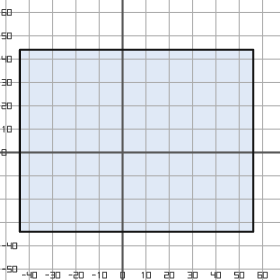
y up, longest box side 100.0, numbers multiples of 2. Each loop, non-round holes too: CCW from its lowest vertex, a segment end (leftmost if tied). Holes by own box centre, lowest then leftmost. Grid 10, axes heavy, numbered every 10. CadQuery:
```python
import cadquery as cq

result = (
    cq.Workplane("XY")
    .moveTo(-44.0, -34.0)
    .lineTo(56.0, -34.0)
    .lineTo(56.0, 44.0)
    .lineTo(-44.0, 44.0)
    .close()
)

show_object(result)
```